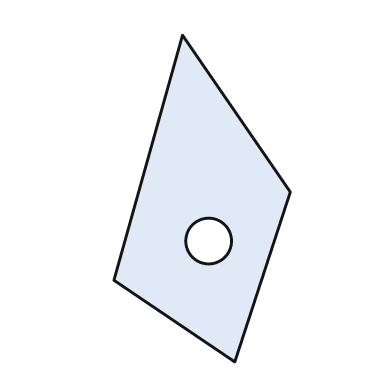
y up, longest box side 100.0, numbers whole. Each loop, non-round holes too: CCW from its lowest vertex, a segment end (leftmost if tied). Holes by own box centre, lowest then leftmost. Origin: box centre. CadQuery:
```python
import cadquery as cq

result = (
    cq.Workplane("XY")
    .moveTo(10.0, -50.0)
    .lineTo(27.0, 2.0)
    .lineTo(-6.0, 50.0)
    .lineTo(-27.0, -25.0)
    .close()
    .moveTo(2.0, -13.0)
    .circle(7.0)
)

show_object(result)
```